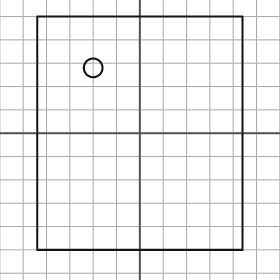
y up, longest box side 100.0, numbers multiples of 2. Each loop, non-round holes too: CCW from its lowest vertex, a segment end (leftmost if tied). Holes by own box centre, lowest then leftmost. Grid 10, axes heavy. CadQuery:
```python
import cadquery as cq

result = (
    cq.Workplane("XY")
    .moveTo(-44.0, -50.0)
    .lineTo(44.0, -50.0)
    .lineTo(44.0, 50.0)
    .lineTo(-44.0, 50.0)
    .close()
    .moveTo(-20.0, 28.0)
    .circle(4.0)
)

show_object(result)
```